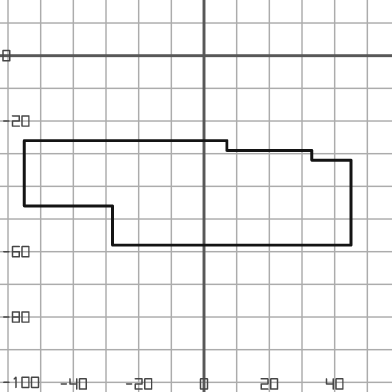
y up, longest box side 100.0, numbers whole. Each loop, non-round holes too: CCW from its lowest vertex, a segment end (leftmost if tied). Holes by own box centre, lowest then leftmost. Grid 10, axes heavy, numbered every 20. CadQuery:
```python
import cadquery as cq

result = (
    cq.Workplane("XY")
    .moveTo(-28.0, -58.0)
    .lineTo(45.0, -58.0)
    .lineTo(45.0, -32.0)
    .lineTo(33.0, -32.0)
    .lineTo(33.0, -29.0)
    .lineTo(7.0, -29.0)
    .lineTo(7.0, -26.0)
    .lineTo(-55.0, -26.0)
    .lineTo(-55.0, -46.0)
    .lineTo(-28.0, -46.0)
    .close()
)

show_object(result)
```